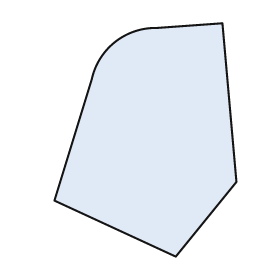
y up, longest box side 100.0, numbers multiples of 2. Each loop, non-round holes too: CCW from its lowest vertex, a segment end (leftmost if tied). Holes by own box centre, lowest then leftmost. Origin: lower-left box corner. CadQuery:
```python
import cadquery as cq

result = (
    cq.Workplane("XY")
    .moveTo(52.0, 0.0)
    .lineTo(78.0, 32.0)
    .lineTo(72.0, 100.0)
    .lineTo(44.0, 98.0)
    .threePointArc((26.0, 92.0), (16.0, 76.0))
    .lineTo(0.0, 24.0)
    .close()
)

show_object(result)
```